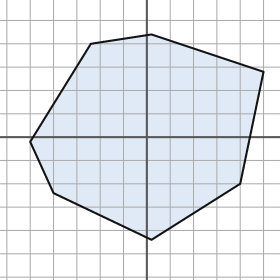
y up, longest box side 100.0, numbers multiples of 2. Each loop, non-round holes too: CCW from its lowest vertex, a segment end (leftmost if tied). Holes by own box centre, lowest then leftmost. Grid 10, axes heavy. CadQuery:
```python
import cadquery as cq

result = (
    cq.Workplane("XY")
    .moveTo(2.0, -44.0)
    .lineTo(40.0, -20.0)
    .lineTo(50.0, 28.0)
    .lineTo(2.0, 44.0)
    .lineTo(-24.0, 40.0)
    .lineTo(-50.0, -2.0)
    .lineTo(-40.0, -24.0)
    .close()
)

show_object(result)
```